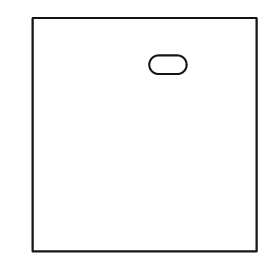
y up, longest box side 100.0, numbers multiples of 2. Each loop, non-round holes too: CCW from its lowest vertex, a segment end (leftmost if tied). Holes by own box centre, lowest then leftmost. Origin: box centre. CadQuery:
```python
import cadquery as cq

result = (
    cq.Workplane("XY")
    .moveTo(-48.0, -50.0)
    .lineTo(48.0, -50.0)
    .lineTo(48.0, 50.0)
    .lineTo(-48.0, 50.0)
    .close()
    .moveTo(6.0, 26.0)
    .lineTo(14.0, 26.0)
    .threePointArc((18.0, 30.0), (14.0, 34.0))
    .lineTo(6.0, 34.0)
    .threePointArc((2.0, 30.0), (6.0, 26.0))
    .close()
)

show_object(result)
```